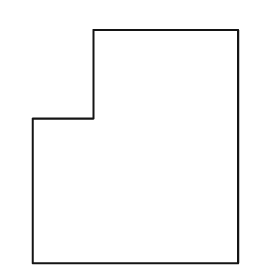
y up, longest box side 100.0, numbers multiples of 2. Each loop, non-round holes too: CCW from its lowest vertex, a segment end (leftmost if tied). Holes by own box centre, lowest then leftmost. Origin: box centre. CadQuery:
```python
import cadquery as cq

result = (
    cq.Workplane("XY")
    .moveTo(-44.0, -50.0)
    .lineTo(44.0, -50.0)
    .lineTo(44.0, 50.0)
    .lineTo(-18.0, 50.0)
    .lineTo(-18.0, 12.0)
    .lineTo(-44.0, 12.0)
    .close()
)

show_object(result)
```